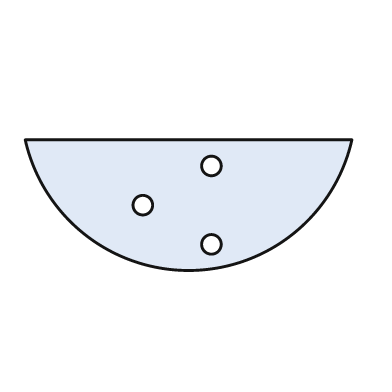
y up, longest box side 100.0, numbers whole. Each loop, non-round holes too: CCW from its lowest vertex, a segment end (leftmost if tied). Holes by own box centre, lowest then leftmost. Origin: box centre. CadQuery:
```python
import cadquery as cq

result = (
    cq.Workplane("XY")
    .moveTo(-50.0, 20.0)
    .threePointArc((0.0, -20.0), (50.0, 20.0))
    .close()
    .moveTo(7.0, -12.0)
    .circle(3.0)
    .moveTo(-14.0, 0.0)
    .circle(3.0)
    .moveTo(7.0, 12.0)
    .circle(3.0)
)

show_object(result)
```